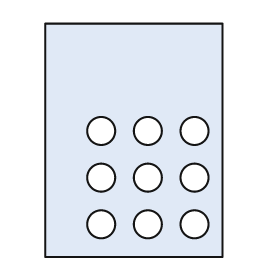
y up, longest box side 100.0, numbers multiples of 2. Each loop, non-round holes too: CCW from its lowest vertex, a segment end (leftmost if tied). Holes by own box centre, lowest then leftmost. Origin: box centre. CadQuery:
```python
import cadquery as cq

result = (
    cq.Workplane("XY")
    .moveTo(-38.0, -50.0)
    .lineTo(38.0, -50.0)
    .lineTo(38.0, 50.0)
    .lineTo(-38.0, 50.0)
    .close()
    .moveTo(-14.0, -36.0)
    .circle(6.0)
    .moveTo(6.0, -36.0)
    .circle(6.0)
    .moveTo(26.0, -36.0)
    .circle(6.0)
    .moveTo(-14.0, -16.0)
    .circle(6.0)
    .moveTo(6.0, -16.0)
    .circle(6.0)
    .moveTo(26.0, -16.0)
    .circle(6.0)
    .moveTo(-14.0, 4.0)
    .circle(6.0)
    .moveTo(6.0, 4.0)
    .circle(6.0)
    .moveTo(26.0, 4.0)
    .circle(6.0)
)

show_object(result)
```